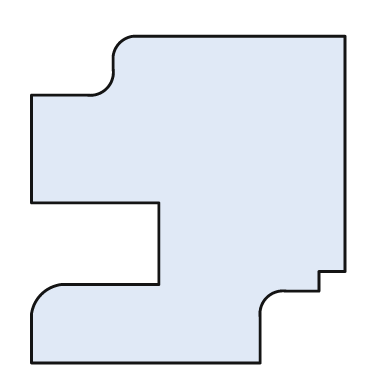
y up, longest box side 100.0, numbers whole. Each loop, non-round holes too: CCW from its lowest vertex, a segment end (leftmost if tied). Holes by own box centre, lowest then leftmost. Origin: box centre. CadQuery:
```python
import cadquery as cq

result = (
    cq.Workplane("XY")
    .moveTo(-48.0, -50.0)
    .lineTo(22.0, -50.0)
    .lineTo(22.0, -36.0)
    .threePointArc((24.0, -30.0), (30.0, -28.0))
    .lineTo(40.0, -28.0)
    .lineTo(40.0, -22.0)
    .lineTo(48.0, -22.0)
    .lineTo(48.0, 50.0)
    .lineTo(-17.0, 50.0)
    .threePointArc((-21.0, 48.0), (-23.0, 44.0))
    .lineTo(-23.0, 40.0)
    .threePointArc((-25.0, 34.0), (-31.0, 32.0))
    .lineTo(-48.0, 32.0)
    .lineTo(-48.0, -1.0)
    .lineTo(-9.0, -1.0)
    .lineTo(-9.0, -26.0)
    .lineTo(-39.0, -26.0)
    .threePointArc((-45.0, -29.0), (-48.0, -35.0))
    .close()
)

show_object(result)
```